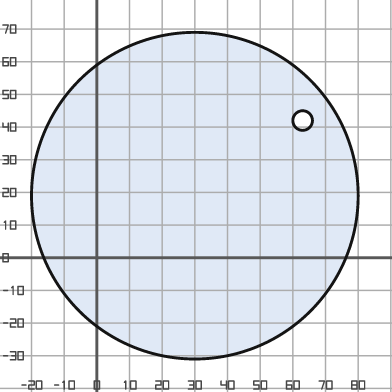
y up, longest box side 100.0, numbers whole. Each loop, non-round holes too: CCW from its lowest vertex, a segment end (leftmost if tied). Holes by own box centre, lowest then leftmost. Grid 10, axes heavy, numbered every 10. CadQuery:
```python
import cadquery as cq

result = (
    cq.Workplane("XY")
    .moveTo(30.0, 19.0)
    .circle(50.0)
    .moveTo(63.0, 42.0)
    .circle(3.0)
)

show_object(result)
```